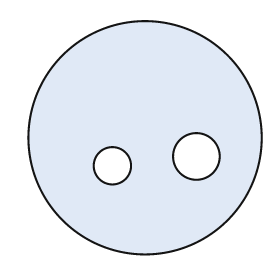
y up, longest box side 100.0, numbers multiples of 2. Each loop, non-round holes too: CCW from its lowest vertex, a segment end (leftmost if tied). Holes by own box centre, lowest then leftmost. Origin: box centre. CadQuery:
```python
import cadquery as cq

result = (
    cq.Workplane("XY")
    .moveTo(0.0, 0.0)
    .circle(50.0)
    .moveTo(-14.0, -12.0)
    .circle(8.0)
    .moveTo(22.0, -8.0)
    .circle(10.0)
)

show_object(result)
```